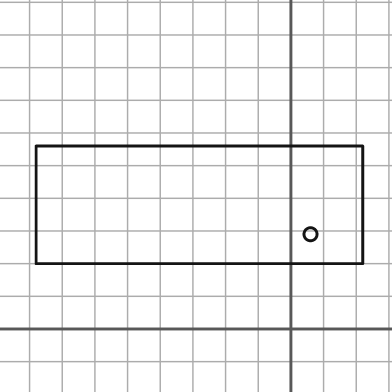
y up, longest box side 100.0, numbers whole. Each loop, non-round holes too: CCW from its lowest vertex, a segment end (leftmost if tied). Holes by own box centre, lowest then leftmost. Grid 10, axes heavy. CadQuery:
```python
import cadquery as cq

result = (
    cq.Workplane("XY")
    .moveTo(-78.0, 20.0)
    .lineTo(22.0, 20.0)
    .lineTo(22.0, 56.0)
    .lineTo(-78.0, 56.0)
    .close()
    .moveTo(6.0, 29.0)
    .circle(2.0)
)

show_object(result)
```